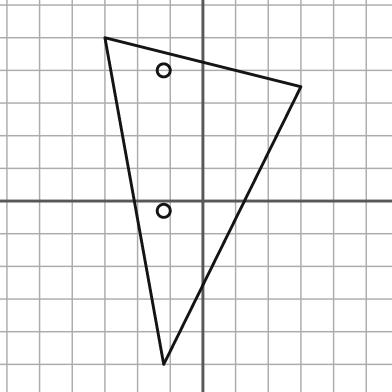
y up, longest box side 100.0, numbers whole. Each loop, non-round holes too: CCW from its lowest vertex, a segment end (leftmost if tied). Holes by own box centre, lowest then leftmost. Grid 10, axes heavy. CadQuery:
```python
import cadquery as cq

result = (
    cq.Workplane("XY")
    .moveTo(-12.0, -50.0)
    .lineTo(30.0, 35.0)
    .lineTo(-30.0, 50.0)
    .close()
    .moveTo(-12.0, -3.0)
    .circle(2.0)
    .moveTo(-12.0, 40.0)
    .circle(2.0)
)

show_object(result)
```